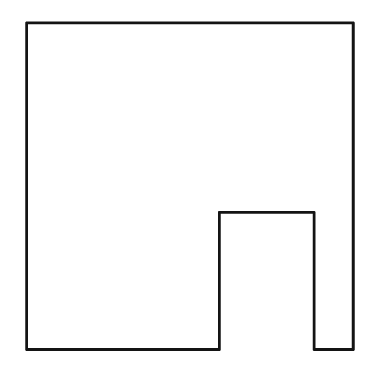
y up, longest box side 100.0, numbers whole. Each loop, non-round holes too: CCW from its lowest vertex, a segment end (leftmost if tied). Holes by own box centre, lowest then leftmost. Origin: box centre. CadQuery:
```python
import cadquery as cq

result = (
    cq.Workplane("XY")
    .moveTo(-50.0, -50.0)
    .lineTo(9.0, -50.0)
    .lineTo(9.0, -8.0)
    .lineTo(38.0, -8.0)
    .lineTo(38.0, -50.0)
    .lineTo(50.0, -50.0)
    .lineTo(50.0, 50.0)
    .lineTo(-50.0, 50.0)
    .close()
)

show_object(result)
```